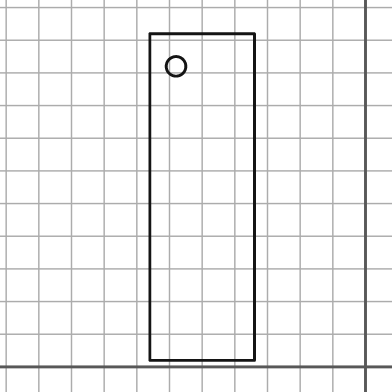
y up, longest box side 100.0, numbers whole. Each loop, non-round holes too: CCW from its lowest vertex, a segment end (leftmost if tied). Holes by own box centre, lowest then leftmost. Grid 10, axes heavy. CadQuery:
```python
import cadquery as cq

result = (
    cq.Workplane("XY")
    .moveTo(-66.0, 2.0)
    .lineTo(-34.0, 2.0)
    .lineTo(-34.0, 102.0)
    .lineTo(-66.0, 102.0)
    .close()
    .moveTo(-58.0, 92.0)
    .circle(3.0)
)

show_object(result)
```